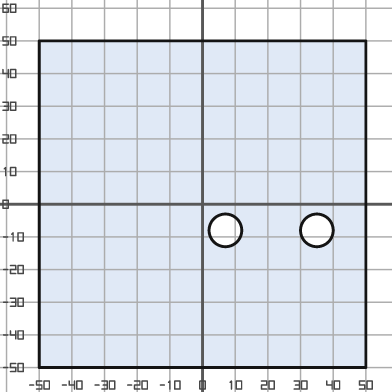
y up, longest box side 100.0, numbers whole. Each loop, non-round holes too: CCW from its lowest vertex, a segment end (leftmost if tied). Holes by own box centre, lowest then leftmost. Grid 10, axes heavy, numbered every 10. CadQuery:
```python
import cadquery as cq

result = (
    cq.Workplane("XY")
    .moveTo(-50.0, -50.0)
    .lineTo(50.0, -50.0)
    .lineTo(50.0, 50.0)
    .lineTo(-50.0, 50.0)
    .close()
    .moveTo(7.0, -8.0)
    .circle(5.0)
    .moveTo(35.0, -8.0)
    .circle(5.0)
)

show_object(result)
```